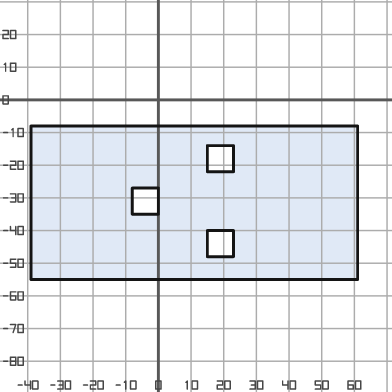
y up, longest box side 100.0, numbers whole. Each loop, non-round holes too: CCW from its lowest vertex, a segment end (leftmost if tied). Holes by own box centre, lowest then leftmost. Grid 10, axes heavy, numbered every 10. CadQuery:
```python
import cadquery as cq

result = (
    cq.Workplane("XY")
    .moveTo(-39.0, -55.0)
    .lineTo(61.0, -55.0)
    .lineTo(61.0, -8.0)
    .lineTo(-39.0, -8.0)
    .close()
    .moveTo(15.0, -48.0)
    .lineTo(23.0, -48.0)
    .lineTo(23.0, -40.0)
    .lineTo(15.0, -40.0)
    .close()
    .moveTo(-8.0, -35.0)
    .lineTo(0.0, -35.0)
    .lineTo(0.0, -27.0)
    .lineTo(-8.0, -27.0)
    .close()
    .moveTo(15.0, -22.0)
    .lineTo(23.0, -22.0)
    .lineTo(23.0, -14.0)
    .lineTo(15.0, -14.0)
    .close()
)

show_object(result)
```